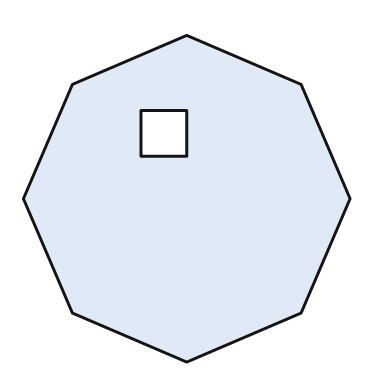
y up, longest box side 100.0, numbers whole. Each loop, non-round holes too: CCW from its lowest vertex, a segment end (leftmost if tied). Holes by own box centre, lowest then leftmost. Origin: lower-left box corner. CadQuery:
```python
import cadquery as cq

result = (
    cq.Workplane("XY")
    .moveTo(50.0, 0.0)
    .lineTo(85.0, 15.0)
    .lineTo(100.0, 50.0)
    .lineTo(85.0, 85.0)
    .lineTo(50.0, 100.0)
    .lineTo(15.0, 85.0)
    .lineTo(0.0, 50.0)
    .lineTo(15.0, 15.0)
    .close()
    .moveTo(36.0, 63.0)
    .lineTo(50.0, 63.0)
    .lineTo(50.0, 77.0)
    .lineTo(36.0, 77.0)
    .close()
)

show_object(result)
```